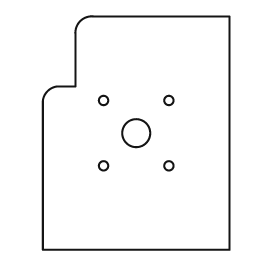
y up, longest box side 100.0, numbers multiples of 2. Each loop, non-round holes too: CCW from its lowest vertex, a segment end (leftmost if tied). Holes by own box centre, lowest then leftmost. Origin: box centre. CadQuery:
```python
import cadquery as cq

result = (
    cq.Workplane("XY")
    .moveTo(-40.0, -50.0)
    .lineTo(40.0, -50.0)
    .lineTo(40.0, 50.0)
    .lineTo(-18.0, 50.0)
    .threePointArc((-24.0, 48.0), (-26.0, 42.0))
    .lineTo(-26.0, 20.0)
    .lineTo(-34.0, 20.0)
    .threePointArc((-38.0, 18.0), (-40.0, 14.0))
    .close()
    .moveTo(-14.0, -14.0)
    .circle(2.0)
    .moveTo(14.0, -14.0)
    .circle(2.0)
    .moveTo(0.0, 0.0)
    .circle(6.0)
    .moveTo(-14.0, 14.0)
    .circle(2.0)
    .moveTo(14.0, 14.0)
    .circle(2.0)
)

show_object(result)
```